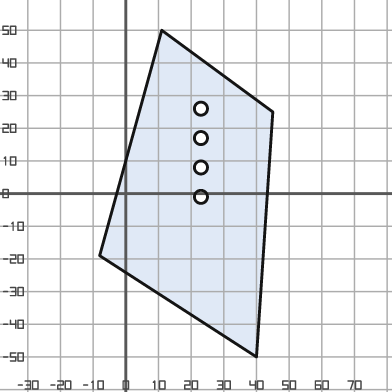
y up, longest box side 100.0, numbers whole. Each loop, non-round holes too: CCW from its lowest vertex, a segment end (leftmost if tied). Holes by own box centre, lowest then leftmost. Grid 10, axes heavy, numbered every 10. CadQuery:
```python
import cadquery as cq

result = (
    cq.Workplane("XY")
    .moveTo(40.0, -50.0)
    .lineTo(45.0, 25.0)
    .lineTo(11.0, 50.0)
    .lineTo(-8.0, -19.0)
    .close()
    .moveTo(23.0, -1.0)
    .circle(2.0)
    .moveTo(23.0, 8.0)
    .circle(2.0)
    .moveTo(23.0, 17.0)
    .circle(2.0)
    .moveTo(23.0, 26.0)
    .circle(2.0)
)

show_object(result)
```